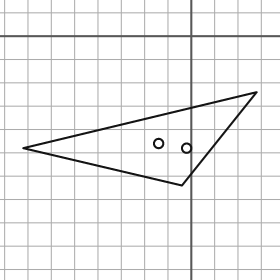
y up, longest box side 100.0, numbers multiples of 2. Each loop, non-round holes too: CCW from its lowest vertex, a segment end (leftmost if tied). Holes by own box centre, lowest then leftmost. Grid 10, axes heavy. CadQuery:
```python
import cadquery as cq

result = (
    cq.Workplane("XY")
    .moveTo(-4.0, -64.0)
    .lineTo(28.0, -24.0)
    .lineTo(-72.0, -48.0)
    .close()
    .moveTo(-2.0, -48.0)
    .circle(2.0)
    .moveTo(-14.0, -46.0)
    .circle(2.0)
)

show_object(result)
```